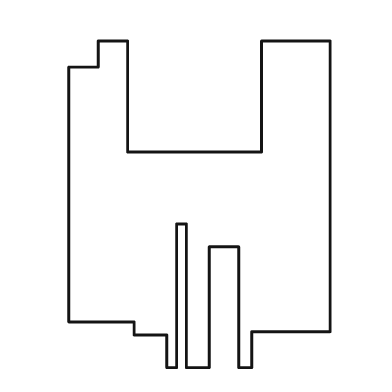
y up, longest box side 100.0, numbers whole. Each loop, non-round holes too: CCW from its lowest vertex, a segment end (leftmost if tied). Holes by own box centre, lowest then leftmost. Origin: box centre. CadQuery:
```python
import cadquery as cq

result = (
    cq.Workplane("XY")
    .moveTo(-10.0, -50.0)
    .lineTo(-7.0, -50.0)
    .lineTo(-7.0, -6.0)
    .lineTo(-4.0, -6.0)
    .lineTo(-4.0, -50.0)
    .lineTo(3.0, -50.0)
    .lineTo(3.0, -13.0)
    .lineTo(12.0, -13.0)
    .lineTo(12.0, -50.0)
    .lineTo(16.0, -50.0)
    .lineTo(16.0, -39.0)
    .lineTo(40.0, -39.0)
    .lineTo(40.0, 50.0)
    .lineTo(19.0, 50.0)
    .lineTo(19.0, 16.0)
    .lineTo(-22.0, 16.0)
    .lineTo(-22.0, 50.0)
    .lineTo(-31.0, 50.0)
    .lineTo(-31.0, 42.0)
    .lineTo(-40.0, 42.0)
    .lineTo(-40.0, -36.0)
    .lineTo(-20.0, -36.0)
    .lineTo(-20.0, -40.0)
    .lineTo(-10.0, -40.0)
    .close()
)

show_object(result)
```